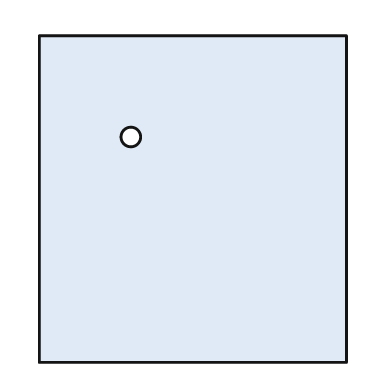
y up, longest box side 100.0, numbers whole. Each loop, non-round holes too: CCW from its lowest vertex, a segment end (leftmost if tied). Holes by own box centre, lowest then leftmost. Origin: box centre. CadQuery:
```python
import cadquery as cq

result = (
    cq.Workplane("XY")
    .moveTo(-47.0, -50.0)
    .lineTo(47.0, -50.0)
    .lineTo(47.0, 50.0)
    .lineTo(-47.0, 50.0)
    .close()
    .moveTo(-19.0, 19.0)
    .circle(3.0)
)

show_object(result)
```